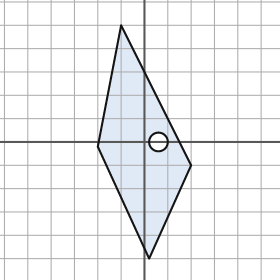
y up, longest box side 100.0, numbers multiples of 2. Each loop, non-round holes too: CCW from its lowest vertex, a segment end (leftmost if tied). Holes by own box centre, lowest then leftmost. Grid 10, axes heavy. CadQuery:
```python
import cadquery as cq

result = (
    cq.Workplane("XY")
    .moveTo(2.0, -50.0)
    .lineTo(20.0, -10.0)
    .lineTo(-10.0, 50.0)
    .lineTo(-20.0, -2.0)
    .close()
    .moveTo(6.0, 0.0)
    .circle(4.0)
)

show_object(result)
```